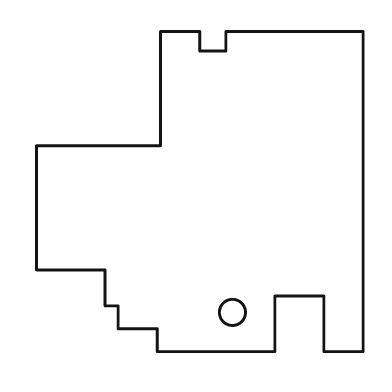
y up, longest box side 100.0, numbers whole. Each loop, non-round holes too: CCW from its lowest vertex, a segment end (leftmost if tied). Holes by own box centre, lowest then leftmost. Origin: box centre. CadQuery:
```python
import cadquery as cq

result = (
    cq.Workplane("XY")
    .moveTo(-13.0, -49.0)
    .lineTo(23.0, -49.0)
    .lineTo(23.0, -32.0)
    .lineTo(38.0, -32.0)
    .lineTo(38.0, -49.0)
    .lineTo(50.0, -49.0)
    .lineTo(50.0, 49.0)
    .lineTo(8.0, 49.0)
    .lineTo(8.0, 43.0)
    .lineTo(0.0, 43.0)
    .lineTo(0.0, 49.0)
    .lineTo(-12.0, 49.0)
    .lineTo(-12.0, 14.0)
    .lineTo(-50.0, 14.0)
    .lineTo(-50.0, -24.0)
    .lineTo(-29.0, -24.0)
    .lineTo(-29.0, -35.0)
    .lineTo(-25.0, -35.0)
    .lineTo(-25.0, -42.0)
    .lineTo(-13.0, -42.0)
    .close()
    .moveTo(10.0, -37.0)
    .circle(4.0)
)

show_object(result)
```